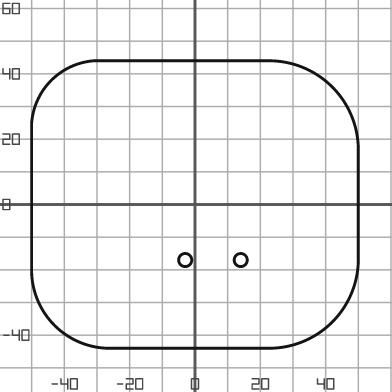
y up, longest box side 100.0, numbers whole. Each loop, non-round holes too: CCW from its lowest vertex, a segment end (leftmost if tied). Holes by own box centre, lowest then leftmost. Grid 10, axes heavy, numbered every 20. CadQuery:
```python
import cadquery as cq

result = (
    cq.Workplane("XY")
    .moveTo(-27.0, -44.0)
    .lineTo(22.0, -44.0)
    .threePointArc((42.0, -36.0), (50.0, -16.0))
    .lineTo(50.0, 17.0)
    .threePointArc((42.0, 36.0), (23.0, 44.0))
    .lineTo(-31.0, 44.0)
    .threePointArc((-44.0, 38.0), (-50.0, 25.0))
    .lineTo(-50.0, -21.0)
    .threePointArc((-43.0, -37.0), (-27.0, -44.0))
    .close()
    .moveTo(-3.0, -17.0)
    .circle(2.0)
    .moveTo(14.0, -17.0)
    .circle(2.0)
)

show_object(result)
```